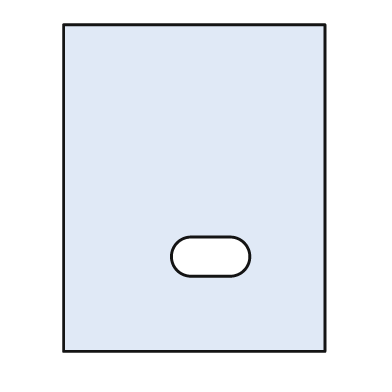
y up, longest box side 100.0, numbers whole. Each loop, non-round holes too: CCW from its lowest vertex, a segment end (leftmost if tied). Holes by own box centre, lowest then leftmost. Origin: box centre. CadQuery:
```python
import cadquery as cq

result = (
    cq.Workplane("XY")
    .moveTo(-40.0, -50.0)
    .lineTo(40.0, -50.0)
    .lineTo(40.0, 50.0)
    .lineTo(-40.0, 50.0)
    .close()
    .moveTo(-1.0, -27.0)
    .lineTo(11.0, -27.0)
    .threePointArc((17.0, -21.0), (11.0, -15.0))
    .lineTo(-1.0, -15.0)
    .threePointArc((-7.0, -21.0), (-1.0, -27.0))
    .close()
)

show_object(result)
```